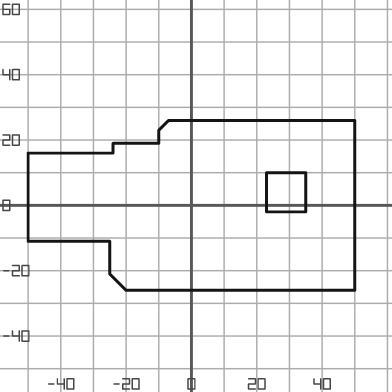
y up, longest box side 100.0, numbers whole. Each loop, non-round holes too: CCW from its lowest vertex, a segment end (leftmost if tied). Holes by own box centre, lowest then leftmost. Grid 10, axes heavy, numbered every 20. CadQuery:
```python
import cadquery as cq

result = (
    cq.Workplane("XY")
    .moveTo(-20.0, -26.0)
    .lineTo(50.0, -26.0)
    .lineTo(50.0, 26.0)
    .lineTo(-7.0, 26.0)
    .lineTo(-10.0, 23.0)
    .lineTo(-10.0, 19.0)
    .lineTo(-24.0, 19.0)
    .lineTo(-24.0, 16.0)
    .lineTo(-50.0, 16.0)
    .lineTo(-50.0, -11.0)
    .lineTo(-25.0, -11.0)
    .lineTo(-25.0, -21.0)
    .close()
    .moveTo(23.0, -2.0)
    .lineTo(35.0, -2.0)
    .lineTo(35.0, 10.0)
    .lineTo(23.0, 10.0)
    .close()
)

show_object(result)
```